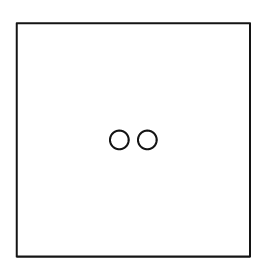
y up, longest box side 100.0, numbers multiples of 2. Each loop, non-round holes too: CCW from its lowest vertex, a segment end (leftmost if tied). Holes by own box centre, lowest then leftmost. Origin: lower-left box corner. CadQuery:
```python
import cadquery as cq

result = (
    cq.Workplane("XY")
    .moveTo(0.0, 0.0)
    .lineTo(100.0, 0.0)
    .lineTo(100.0, 100.0)
    .lineTo(0.0, 100.0)
    .close()
    .moveTo(44.0, 50.0)
    .circle(4.0)
    .moveTo(56.0, 50.0)
    .circle(4.0)
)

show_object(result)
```